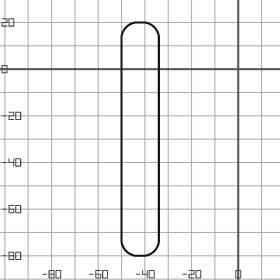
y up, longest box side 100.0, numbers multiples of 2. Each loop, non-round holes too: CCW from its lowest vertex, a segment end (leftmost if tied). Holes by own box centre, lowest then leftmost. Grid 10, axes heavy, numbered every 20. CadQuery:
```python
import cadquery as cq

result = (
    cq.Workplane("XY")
    .moveTo(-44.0, -80.0)
    .lineTo(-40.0, -80.0)
    .threePointArc((-36.0, -78.0), (-34.0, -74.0))
    .lineTo(-34.0, 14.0)
    .threePointArc((-36.0, 18.0), (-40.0, 20.0))
    .lineTo(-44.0, 20.0)
    .threePointArc((-48.0, 18.0), (-50.0, 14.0))
    .lineTo(-50.0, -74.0)
    .threePointArc((-48.0, -78.0), (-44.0, -80.0))
    .close()
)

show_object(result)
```